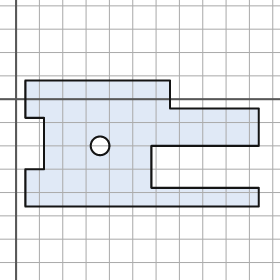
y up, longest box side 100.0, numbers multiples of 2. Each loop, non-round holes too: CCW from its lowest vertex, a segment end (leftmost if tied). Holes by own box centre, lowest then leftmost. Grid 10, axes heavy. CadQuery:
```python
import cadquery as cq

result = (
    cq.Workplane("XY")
    .moveTo(4.0, -46.0)
    .lineTo(104.0, -46.0)
    .lineTo(104.0, -38.0)
    .lineTo(58.0, -38.0)
    .lineTo(58.0, -20.0)
    .lineTo(104.0, -20.0)
    .lineTo(104.0, -4.0)
    .lineTo(66.0, -4.0)
    .lineTo(66.0, 8.0)
    .lineTo(4.0, 8.0)
    .lineTo(4.0, -8.0)
    .lineTo(12.0, -8.0)
    .lineTo(12.0, -30.0)
    .lineTo(4.0, -30.0)
    .close()
    .moveTo(36.0, -20.0)
    .circle(4.0)
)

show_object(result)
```